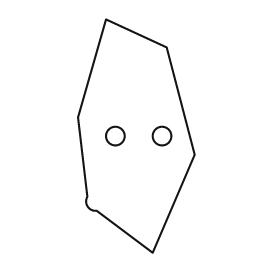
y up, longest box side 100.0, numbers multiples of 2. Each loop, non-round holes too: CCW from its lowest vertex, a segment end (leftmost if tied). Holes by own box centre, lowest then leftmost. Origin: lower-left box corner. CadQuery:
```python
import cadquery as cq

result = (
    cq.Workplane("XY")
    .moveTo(32.0, 0.0)
    .lineTo(50.0, 42.0)
    .lineTo(38.0, 88.0)
    .lineTo(12.0, 100.0)
    .lineTo(0.0, 58.0)
    .lineTo(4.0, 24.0)
    .threePointArc((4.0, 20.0), (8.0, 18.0))
    .close()
    .moveTo(16.0, 50.0)
    .circle(4.0)
    .moveTo(36.0, 50.0)
    .circle(4.0)
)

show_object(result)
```